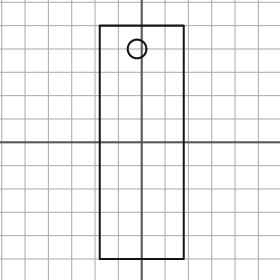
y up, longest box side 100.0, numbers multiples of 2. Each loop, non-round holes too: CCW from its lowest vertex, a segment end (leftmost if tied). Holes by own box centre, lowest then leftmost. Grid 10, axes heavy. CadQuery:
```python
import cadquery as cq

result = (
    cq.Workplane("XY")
    .moveTo(-18.0, -50.0)
    .lineTo(18.0, -50.0)
    .lineTo(18.0, 50.0)
    .lineTo(-18.0, 50.0)
    .close()
    .moveTo(-2.0, 40.0)
    .circle(4.0)
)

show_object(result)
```